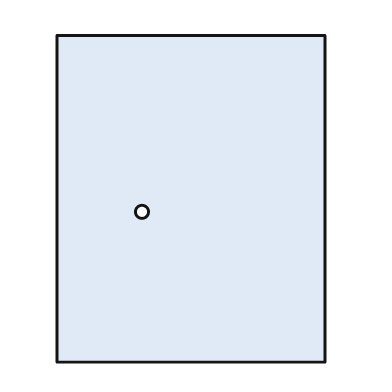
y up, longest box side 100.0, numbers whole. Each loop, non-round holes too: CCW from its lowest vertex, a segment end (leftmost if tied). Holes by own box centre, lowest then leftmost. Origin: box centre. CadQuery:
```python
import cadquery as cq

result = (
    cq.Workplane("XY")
    .moveTo(-41.0, -50.0)
    .lineTo(41.0, -50.0)
    .lineTo(41.0, 50.0)
    .lineTo(-41.0, 50.0)
    .close()
    .moveTo(-15.0, -4.0)
    .circle(2.0)
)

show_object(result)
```